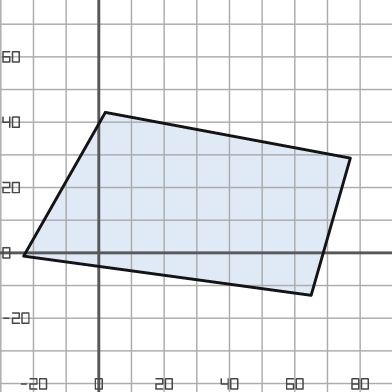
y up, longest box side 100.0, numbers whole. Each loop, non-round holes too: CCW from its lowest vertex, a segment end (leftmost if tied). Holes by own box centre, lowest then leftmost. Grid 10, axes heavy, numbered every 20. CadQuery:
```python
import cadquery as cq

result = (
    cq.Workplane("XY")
    .moveTo(65.0, -13.0)
    .lineTo(77.0, 29.0)
    .lineTo(2.0, 43.0)
    .lineTo(-23.0, -1.0)
    .close()
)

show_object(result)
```